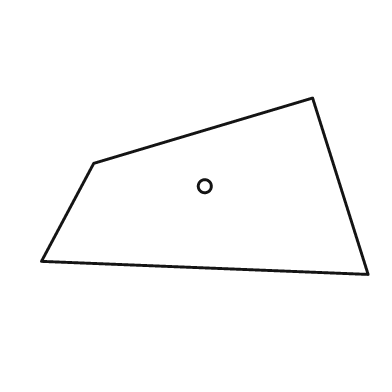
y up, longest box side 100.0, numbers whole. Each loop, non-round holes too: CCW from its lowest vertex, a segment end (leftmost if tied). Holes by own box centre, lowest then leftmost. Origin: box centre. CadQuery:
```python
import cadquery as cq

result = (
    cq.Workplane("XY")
    .moveTo(50.0, -27.0)
    .lineTo(33.0, 27.0)
    .lineTo(-34.0, 7.0)
    .lineTo(-50.0, -23.0)
    .close()
    .moveTo(0.0, 0.0)
    .circle(2.0)
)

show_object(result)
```